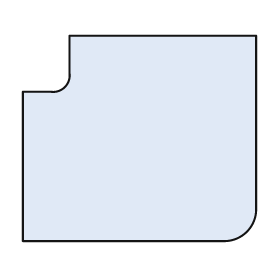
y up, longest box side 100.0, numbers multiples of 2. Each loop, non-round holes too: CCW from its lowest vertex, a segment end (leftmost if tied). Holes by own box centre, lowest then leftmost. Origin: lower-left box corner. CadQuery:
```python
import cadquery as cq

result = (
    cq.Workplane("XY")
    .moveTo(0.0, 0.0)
    .lineTo(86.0, 0.0)
    .threePointArc((96.0, 4.0), (100.0, 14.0))
    .lineTo(100.0, 88.0)
    .lineTo(20.0, 88.0)
    .lineTo(20.0, 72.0)
    .threePointArc((18.0, 66.0), (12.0, 64.0))
    .lineTo(0.0, 64.0)
    .close()
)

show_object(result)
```